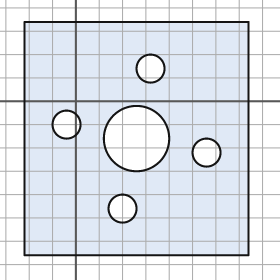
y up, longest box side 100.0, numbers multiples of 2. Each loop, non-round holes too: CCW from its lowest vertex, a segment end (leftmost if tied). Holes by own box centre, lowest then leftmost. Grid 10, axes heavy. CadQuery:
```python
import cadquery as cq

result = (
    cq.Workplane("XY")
    .moveTo(-22.0, -66.0)
    .lineTo(74.0, -66.0)
    .lineTo(74.0, 34.0)
    .lineTo(-22.0, 34.0)
    .close()
    .moveTo(20.0, -46.0)
    .circle(6.0)
    .moveTo(56.0, -22.0)
    .circle(6.0)
    .moveTo(26.0, -16.0)
    .circle(14.0)
    .moveTo(-4.0, -10.0)
    .circle(6.0)
    .moveTo(32.0, 14.0)
    .circle(6.0)
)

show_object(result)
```